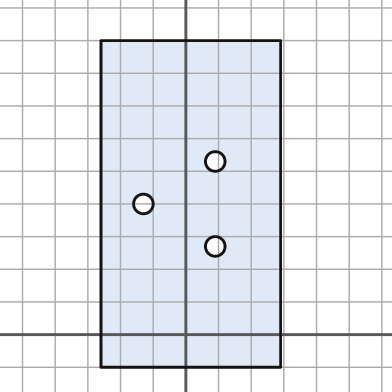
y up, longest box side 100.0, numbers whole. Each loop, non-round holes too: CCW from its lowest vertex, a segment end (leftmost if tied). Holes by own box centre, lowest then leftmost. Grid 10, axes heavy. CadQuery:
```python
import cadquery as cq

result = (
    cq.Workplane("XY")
    .moveTo(-26.0, -10.0)
    .lineTo(29.0, -10.0)
    .lineTo(29.0, 90.0)
    .lineTo(-26.0, 90.0)
    .close()
    .moveTo(9.0, 27.0)
    .circle(3.0)
    .moveTo(-13.0, 40.0)
    .circle(3.0)
    .moveTo(9.0, 53.0)
    .circle(3.0)
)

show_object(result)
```